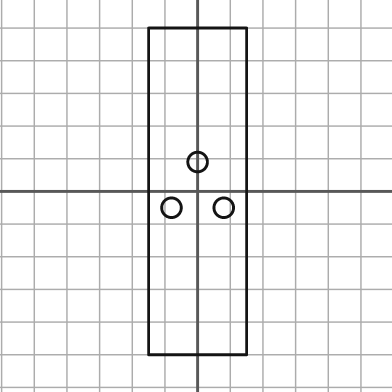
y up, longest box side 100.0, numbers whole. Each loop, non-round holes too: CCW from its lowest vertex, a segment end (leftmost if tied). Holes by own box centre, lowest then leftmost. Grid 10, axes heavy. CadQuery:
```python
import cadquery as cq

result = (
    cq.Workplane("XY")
    .moveTo(-15.0, -50.0)
    .lineTo(15.0, -50.0)
    .lineTo(15.0, 50.0)
    .lineTo(-15.0, 50.0)
    .close()
    .moveTo(-8.0, -5.0)
    .circle(3.0)
    .moveTo(8.0, -5.0)
    .circle(3.0)
    .moveTo(0.0, 9.0)
    .circle(3.0)
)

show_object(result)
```